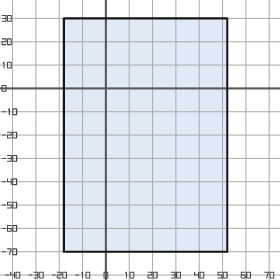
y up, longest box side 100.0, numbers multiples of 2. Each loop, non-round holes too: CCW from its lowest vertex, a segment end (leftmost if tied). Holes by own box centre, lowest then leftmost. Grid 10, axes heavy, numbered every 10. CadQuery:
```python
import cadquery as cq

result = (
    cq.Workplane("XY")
    .moveTo(-18.0, -70.0)
    .lineTo(52.0, -70.0)
    .lineTo(52.0, 30.0)
    .lineTo(-18.0, 30.0)
    .close()
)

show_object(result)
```